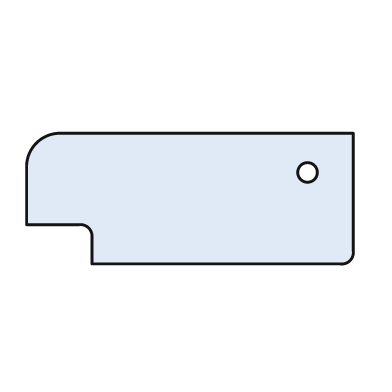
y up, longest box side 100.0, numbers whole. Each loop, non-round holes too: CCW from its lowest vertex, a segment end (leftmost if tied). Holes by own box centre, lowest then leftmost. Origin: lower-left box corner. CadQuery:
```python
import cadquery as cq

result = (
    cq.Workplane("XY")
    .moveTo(20.0, 0.0)
    .lineTo(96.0, 0.0)
    .threePointArc((99.0, 1.0), (100.0, 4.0))
    .lineTo(100.0, 40.0)
    .lineTo(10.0, 40.0)
    .threePointArc((3.0, 37.0), (0.0, 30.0))
    .lineTo(0.0, 12.0)
    .lineTo(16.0, 12.0)
    .threePointArc((19.0, 11.0), (20.0, 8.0))
    .close()
    .moveTo(86.0, 28.0)
    .circle(3.0)
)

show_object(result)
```